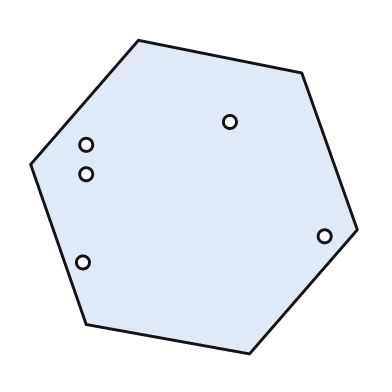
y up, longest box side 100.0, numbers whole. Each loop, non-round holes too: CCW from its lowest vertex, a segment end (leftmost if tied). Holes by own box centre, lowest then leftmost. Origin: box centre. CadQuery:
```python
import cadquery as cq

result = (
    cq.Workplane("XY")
    .moveTo(17.0, -48.0)
    .lineTo(50.0, -10.0)
    .lineTo(33.0, 38.0)
    .lineTo(-17.0, 48.0)
    .lineTo(-50.0, 10.0)
    .lineTo(-33.0, -39.0)
    .close()
    .moveTo(-34.0, -20.0)
    .circle(2.0)
    .moveTo(40.0, -12.0)
    .circle(2.0)
    .moveTo(-33.0, 7.0)
    .circle(2.0)
    .moveTo(-33.0, 16.0)
    .circle(2.0)
    .moveTo(11.0, 23.0)
    .circle(2.0)
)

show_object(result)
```